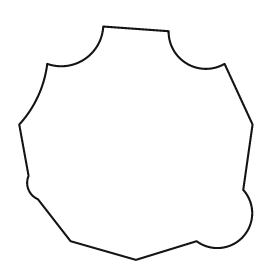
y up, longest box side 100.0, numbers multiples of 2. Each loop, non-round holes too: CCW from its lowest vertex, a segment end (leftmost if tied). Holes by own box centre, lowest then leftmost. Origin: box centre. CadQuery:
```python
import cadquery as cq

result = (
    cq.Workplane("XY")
    .moveTo(0.0, -50.0)
    .lineTo(26.0, -42.0)
    .threePointArc((46.0, -40.0), (46.0, -20.0))
    .lineTo(50.0, 8.0)
    .lineTo(38.0, 34.0)
    .threePointArc((22.0, 34.0), (14.0, 48.0))
    .lineTo(-14.0, 50.0)
    .threePointArc((-22.0, 36.0), (-38.0, 34.0))
    .threePointArc((-42.0, 20.0), (-50.0, 8.0))
    .lineTo(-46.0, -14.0)
    .threePointArc((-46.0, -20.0), (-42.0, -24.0))
    .lineTo(-28.0, -42.0)
    .close()
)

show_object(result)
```